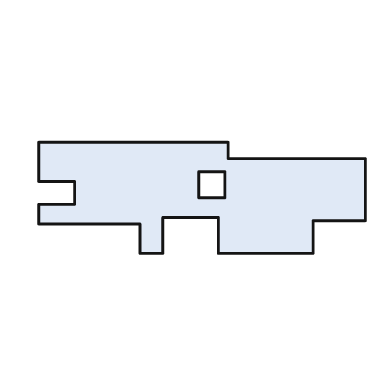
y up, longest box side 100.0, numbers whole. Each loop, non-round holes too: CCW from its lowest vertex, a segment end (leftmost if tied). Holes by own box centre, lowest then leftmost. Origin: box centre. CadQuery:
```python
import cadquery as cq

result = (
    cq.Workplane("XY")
    .moveTo(-19.0, -17.0)
    .lineTo(-12.0, -17.0)
    .lineTo(-12.0, -6.0)
    .lineTo(5.0, -6.0)
    .lineTo(5.0, -17.0)
    .lineTo(34.0, -17.0)
    .lineTo(34.0, -7.0)
    .lineTo(50.0, -7.0)
    .lineTo(50.0, 12.0)
    .lineTo(8.0, 12.0)
    .lineTo(8.0, 17.0)
    .lineTo(-50.0, 17.0)
    .lineTo(-50.0, 5.0)
    .lineTo(-39.0, 5.0)
    .lineTo(-39.0, -2.0)
    .lineTo(-50.0, -2.0)
    .lineTo(-50.0, -8.0)
    .lineTo(-19.0, -8.0)
    .close()
    .moveTo(-1.0, 0.0)
    .lineTo(7.0, 0.0)
    .lineTo(7.0, 8.0)
    .lineTo(-1.0, 8.0)
    .close()
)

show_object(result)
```